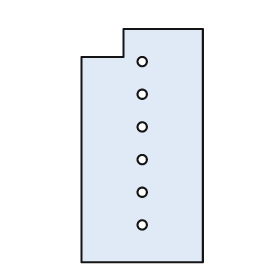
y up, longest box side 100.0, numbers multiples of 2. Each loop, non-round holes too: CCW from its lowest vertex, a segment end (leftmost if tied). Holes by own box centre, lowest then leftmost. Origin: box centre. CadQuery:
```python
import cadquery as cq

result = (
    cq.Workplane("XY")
    .moveTo(-26.0, -50.0)
    .lineTo(26.0, -50.0)
    .lineTo(26.0, 50.0)
    .lineTo(-8.0, 50.0)
    .lineTo(-8.0, 38.0)
    .lineTo(-26.0, 38.0)
    .close()
    .moveTo(0.0, -34.0)
    .circle(2.0)
    .moveTo(0.0, -20.0)
    .circle(2.0)
    .moveTo(0.0, -6.0)
    .circle(2.0)
    .moveTo(0.0, 8.0)
    .circle(2.0)
    .moveTo(0.0, 22.0)
    .circle(2.0)
    .moveTo(0.0, 36.0)
    .circle(2.0)
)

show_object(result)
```